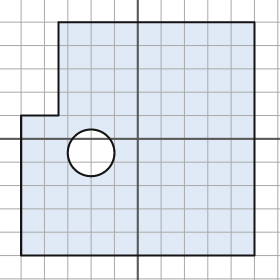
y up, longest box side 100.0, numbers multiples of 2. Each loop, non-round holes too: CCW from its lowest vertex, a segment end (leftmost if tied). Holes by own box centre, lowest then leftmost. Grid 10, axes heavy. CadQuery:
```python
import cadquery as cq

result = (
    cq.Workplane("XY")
    .moveTo(-50.0, -50.0)
    .lineTo(50.0, -50.0)
    .lineTo(50.0, 50.0)
    .lineTo(-34.0, 50.0)
    .lineTo(-34.0, 10.0)
    .lineTo(-50.0, 10.0)
    .close()
    .moveTo(-20.0, -6.0)
    .circle(10.0)
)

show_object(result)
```